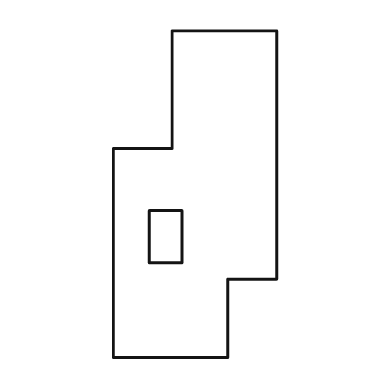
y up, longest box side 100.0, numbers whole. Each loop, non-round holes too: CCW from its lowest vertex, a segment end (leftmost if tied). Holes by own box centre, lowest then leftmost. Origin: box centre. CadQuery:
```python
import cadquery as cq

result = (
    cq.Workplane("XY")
    .moveTo(-25.0, -50.0)
    .lineTo(10.0, -50.0)
    .lineTo(10.0, -26.0)
    .lineTo(25.0, -26.0)
    .lineTo(25.0, 50.0)
    .lineTo(-7.0, 50.0)
    .lineTo(-7.0, 14.0)
    .lineTo(-25.0, 14.0)
    .close()
    .moveTo(-14.0, -21.0)
    .lineTo(-4.0, -21.0)
    .lineTo(-4.0, -5.0)
    .lineTo(-14.0, -5.0)
    .close()
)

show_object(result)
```